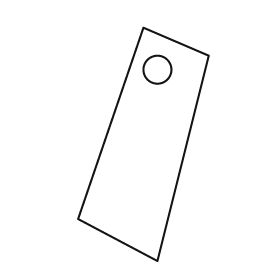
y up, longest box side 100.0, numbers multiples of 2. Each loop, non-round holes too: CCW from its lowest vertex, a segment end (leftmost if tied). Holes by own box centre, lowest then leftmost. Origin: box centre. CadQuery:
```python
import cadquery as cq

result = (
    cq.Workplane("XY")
    .moveTo(6.0, -50.0)
    .lineTo(28.0, 38.0)
    .lineTo(0.0, 50.0)
    .lineTo(-28.0, -32.0)
    .close()
    .moveTo(6.0, 32.0)
    .circle(6.0)
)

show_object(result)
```